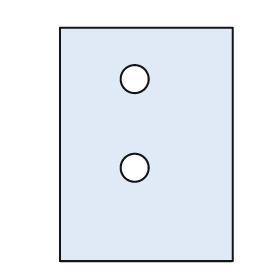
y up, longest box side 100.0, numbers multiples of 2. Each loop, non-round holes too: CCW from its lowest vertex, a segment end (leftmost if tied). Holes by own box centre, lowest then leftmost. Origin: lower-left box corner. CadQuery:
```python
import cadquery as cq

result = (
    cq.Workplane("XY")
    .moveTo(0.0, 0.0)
    .lineTo(74.0, 0.0)
    .lineTo(74.0, 100.0)
    .lineTo(0.0, 100.0)
    .close()
    .moveTo(32.0, 40.0)
    .circle(6.0)
    .moveTo(32.0, 78.0)
    .circle(6.0)
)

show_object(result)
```